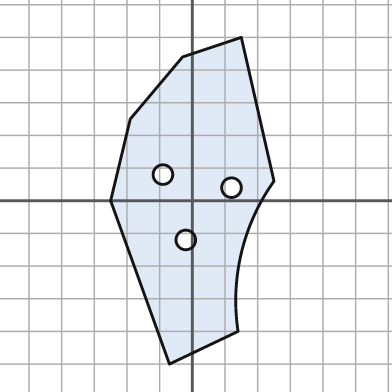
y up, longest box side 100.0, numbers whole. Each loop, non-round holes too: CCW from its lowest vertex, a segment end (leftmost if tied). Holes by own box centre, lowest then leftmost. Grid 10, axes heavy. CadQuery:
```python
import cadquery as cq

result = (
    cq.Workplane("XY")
    .moveTo(-7.0, -50.0)
    .lineTo(14.0, -40.0)
    .threePointArc((15.0, -16.0), (25.0, 6.0))
    .lineTo(15.0, 50.0)
    .lineTo(-3.0, 44.0)
    .lineTo(-19.0, 25.0)
    .lineTo(-25.0, 0.0)
    .close()
    .moveTo(-2.0, -12.0)
    .circle(3.0)
    .moveTo(12.0, 4.0)
    .circle(3.0)
    .moveTo(-9.0, 8.0)
    .circle(3.0)
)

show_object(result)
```